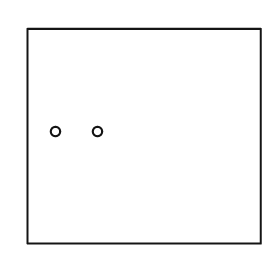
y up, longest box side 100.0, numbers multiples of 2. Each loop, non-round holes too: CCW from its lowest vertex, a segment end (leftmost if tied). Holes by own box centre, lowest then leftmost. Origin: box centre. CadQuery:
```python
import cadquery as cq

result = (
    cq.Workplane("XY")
    .moveTo(-50.0, -46.0)
    .lineTo(50.0, -46.0)
    .lineTo(50.0, 46.0)
    .lineTo(-50.0, 46.0)
    .close()
    .moveTo(-38.0, 2.0)
    .circle(2.0)
    .moveTo(-20.0, 2.0)
    .circle(2.0)
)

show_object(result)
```